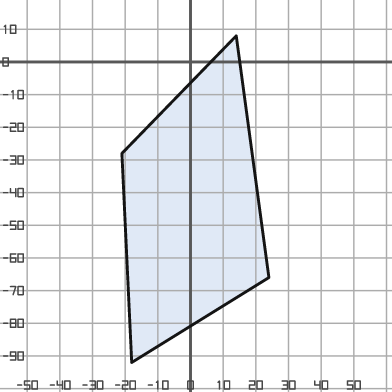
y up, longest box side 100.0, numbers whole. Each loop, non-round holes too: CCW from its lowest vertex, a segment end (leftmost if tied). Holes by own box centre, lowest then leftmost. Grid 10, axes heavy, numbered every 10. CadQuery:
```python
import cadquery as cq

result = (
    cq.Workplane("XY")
    .moveTo(-18.0, -92.0)
    .lineTo(24.0, -66.0)
    .lineTo(14.0, 8.0)
    .lineTo(-21.0, -28.0)
    .close()
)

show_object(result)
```